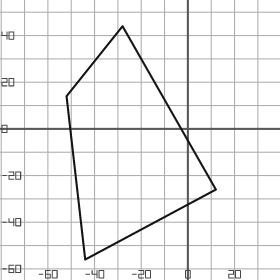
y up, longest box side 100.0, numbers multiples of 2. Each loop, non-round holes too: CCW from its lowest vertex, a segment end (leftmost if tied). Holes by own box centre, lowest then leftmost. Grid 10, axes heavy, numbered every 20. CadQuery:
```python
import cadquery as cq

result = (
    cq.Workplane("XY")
    .moveTo(-44.0, -56.0)
    .lineTo(12.0, -26.0)
    .lineTo(-28.0, 44.0)
    .lineTo(-52.0, 14.0)
    .close()
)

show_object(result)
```